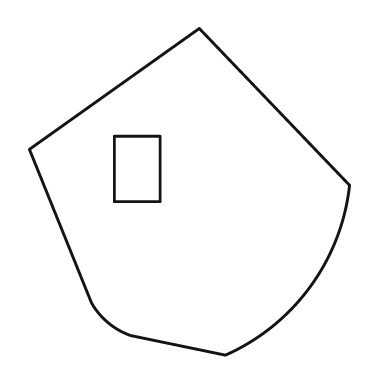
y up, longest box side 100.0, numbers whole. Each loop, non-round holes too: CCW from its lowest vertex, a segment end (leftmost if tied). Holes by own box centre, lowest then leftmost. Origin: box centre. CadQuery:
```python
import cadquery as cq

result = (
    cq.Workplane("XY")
    .moveTo(11.0, -50.0)
    .threePointArc((37.0, -29.0), (49.0, 2.0))
    .lineTo(3.0, 50.0)
    .lineTo(-49.0, 13.0)
    .lineTo(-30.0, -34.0)
    .threePointArc((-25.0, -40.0), (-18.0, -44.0))
    .close()
    .moveTo(-23.0, -3.0)
    .lineTo(-9.0, -3.0)
    .lineTo(-9.0, 17.0)
    .lineTo(-23.0, 17.0)
    .close()
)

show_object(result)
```